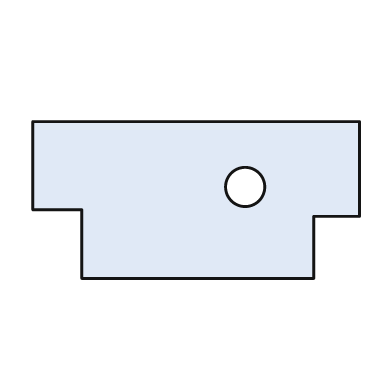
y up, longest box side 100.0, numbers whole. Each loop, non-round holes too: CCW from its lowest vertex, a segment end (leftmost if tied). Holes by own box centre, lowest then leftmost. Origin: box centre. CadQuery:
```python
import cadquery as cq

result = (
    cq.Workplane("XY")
    .moveTo(-35.0, -24.0)
    .lineTo(36.0, -24.0)
    .lineTo(36.0, -5.0)
    .lineTo(50.0, -5.0)
    .lineTo(50.0, 24.0)
    .lineTo(-50.0, 24.0)
    .lineTo(-50.0, -3.0)
    .lineTo(-35.0, -3.0)
    .close()
    .moveTo(15.0, 4.0)
    .circle(6.0)
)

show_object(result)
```